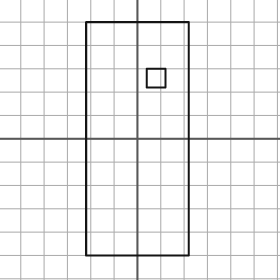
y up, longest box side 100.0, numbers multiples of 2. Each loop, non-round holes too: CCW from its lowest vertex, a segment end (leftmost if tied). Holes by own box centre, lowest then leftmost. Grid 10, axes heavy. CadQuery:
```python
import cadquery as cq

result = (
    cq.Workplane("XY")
    .moveTo(-22.0, -50.0)
    .lineTo(22.0, -50.0)
    .lineTo(22.0, 50.0)
    .lineTo(-22.0, 50.0)
    .close()
    .moveTo(4.0, 22.0)
    .lineTo(12.0, 22.0)
    .lineTo(12.0, 30.0)
    .lineTo(4.0, 30.0)
    .close()
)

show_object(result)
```